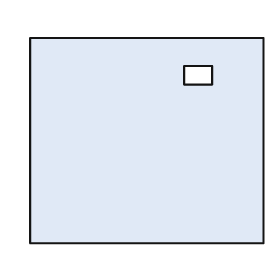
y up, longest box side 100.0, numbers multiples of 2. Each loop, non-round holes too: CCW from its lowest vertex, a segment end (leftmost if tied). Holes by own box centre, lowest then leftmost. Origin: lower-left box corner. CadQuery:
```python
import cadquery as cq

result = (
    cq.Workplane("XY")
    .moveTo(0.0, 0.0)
    .lineTo(100.0, 0.0)
    .lineTo(100.0, 88.0)
    .lineTo(0.0, 88.0)
    .close()
    .moveTo(66.0, 68.0)
    .lineTo(78.0, 68.0)
    .lineTo(78.0, 76.0)
    .lineTo(66.0, 76.0)
    .close()
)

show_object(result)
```